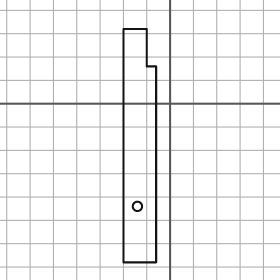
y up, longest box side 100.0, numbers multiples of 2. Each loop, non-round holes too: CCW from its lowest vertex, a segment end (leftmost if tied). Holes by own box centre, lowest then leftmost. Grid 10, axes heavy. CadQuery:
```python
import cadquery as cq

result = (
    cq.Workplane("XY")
    .moveTo(-20.0, -68.0)
    .lineTo(-6.0, -68.0)
    .lineTo(-6.0, 16.0)
    .lineTo(-10.0, 16.0)
    .lineTo(-10.0, 32.0)
    .lineTo(-20.0, 32.0)
    .close()
    .moveTo(-14.0, -44.0)
    .circle(2.0)
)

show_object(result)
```